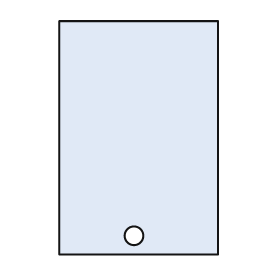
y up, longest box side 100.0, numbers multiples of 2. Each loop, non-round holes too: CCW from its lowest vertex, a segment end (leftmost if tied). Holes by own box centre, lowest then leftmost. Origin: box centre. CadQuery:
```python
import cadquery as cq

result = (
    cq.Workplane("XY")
    .moveTo(-34.0, -50.0)
    .lineTo(34.0, -50.0)
    .lineTo(34.0, 50.0)
    .lineTo(-34.0, 50.0)
    .close()
    .moveTo(-2.0, -42.0)
    .circle(4.0)
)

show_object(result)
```